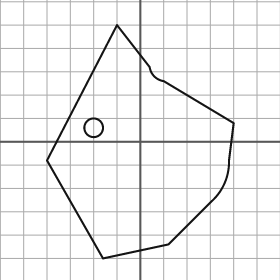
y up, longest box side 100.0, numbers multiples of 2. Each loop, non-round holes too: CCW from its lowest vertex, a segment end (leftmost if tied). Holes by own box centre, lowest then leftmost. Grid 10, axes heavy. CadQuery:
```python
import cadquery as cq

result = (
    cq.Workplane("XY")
    .moveTo(-16.0, -50.0)
    .lineTo(12.0, -44.0)
    .lineTo(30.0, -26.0)
    .threePointArc((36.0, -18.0), (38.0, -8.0))
    .lineTo(40.0, 8.0)
    .lineTo(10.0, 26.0)
    .threePointArc((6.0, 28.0), (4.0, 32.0))
    .lineTo(-10.0, 50.0)
    .lineTo(-40.0, -8.0)
    .close()
    .moveTo(-20.0, 6.0)
    .circle(4.0)
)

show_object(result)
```